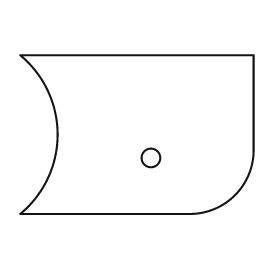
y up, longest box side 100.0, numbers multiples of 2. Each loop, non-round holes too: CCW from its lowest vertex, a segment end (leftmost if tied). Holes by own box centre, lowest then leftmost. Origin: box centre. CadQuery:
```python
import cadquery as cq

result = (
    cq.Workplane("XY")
    .moveTo(-50.0, -34.0)
    .lineTo(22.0, -34.0)
    .threePointArc((42.0, -26.0), (50.0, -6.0))
    .lineTo(50.0, 34.0)
    .lineTo(-50.0, 34.0)
    .threePointArc((-34.0, 0.0), (-50.0, -34.0))
    .close()
    .moveTo(6.0, -10.0)
    .circle(4.0)
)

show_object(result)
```